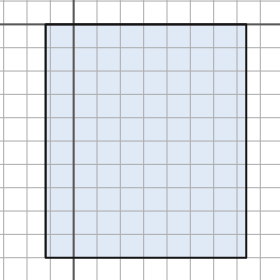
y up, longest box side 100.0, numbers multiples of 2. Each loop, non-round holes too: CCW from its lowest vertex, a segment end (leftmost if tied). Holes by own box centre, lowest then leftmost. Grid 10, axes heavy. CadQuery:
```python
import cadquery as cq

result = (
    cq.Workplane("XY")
    .moveTo(-12.0, -100.0)
    .lineTo(74.0, -100.0)
    .lineTo(74.0, 0.0)
    .lineTo(-12.0, 0.0)
    .close()
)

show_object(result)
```